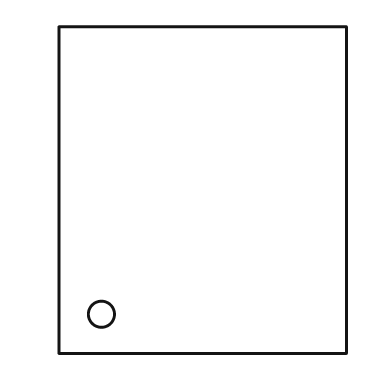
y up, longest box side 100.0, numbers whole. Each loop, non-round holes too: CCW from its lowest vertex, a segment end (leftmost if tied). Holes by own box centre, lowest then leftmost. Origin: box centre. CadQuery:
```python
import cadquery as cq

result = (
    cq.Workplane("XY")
    .moveTo(-44.0, -50.0)
    .lineTo(44.0, -50.0)
    .lineTo(44.0, 50.0)
    .lineTo(-44.0, 50.0)
    .close()
    .moveTo(-31.0, -38.0)
    .circle(4.0)
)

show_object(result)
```